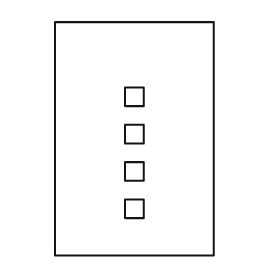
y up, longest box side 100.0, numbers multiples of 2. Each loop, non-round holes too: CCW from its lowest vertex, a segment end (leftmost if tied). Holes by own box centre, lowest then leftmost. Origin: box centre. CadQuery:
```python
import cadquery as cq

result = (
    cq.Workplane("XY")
    .moveTo(-34.0, -50.0)
    .lineTo(34.0, -50.0)
    .lineTo(34.0, 50.0)
    .lineTo(-34.0, 50.0)
    .close()
    .moveTo(-4.0, -34.0)
    .lineTo(4.0, -34.0)
    .lineTo(4.0, -26.0)
    .lineTo(-4.0, -26.0)
    .close()
    .moveTo(-4.0, -18.0)
    .lineTo(4.0, -18.0)
    .lineTo(4.0, -10.0)
    .lineTo(-4.0, -10.0)
    .close()
    .moveTo(-4.0, -2.0)
    .lineTo(4.0, -2.0)
    .lineTo(4.0, 6.0)
    .lineTo(-4.0, 6.0)
    .close()
    .moveTo(-4.0, 14.0)
    .lineTo(4.0, 14.0)
    .lineTo(4.0, 22.0)
    .lineTo(-4.0, 22.0)
    .close()
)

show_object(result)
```